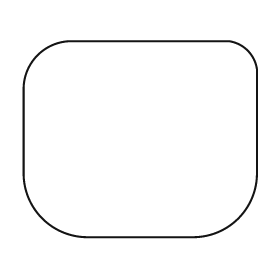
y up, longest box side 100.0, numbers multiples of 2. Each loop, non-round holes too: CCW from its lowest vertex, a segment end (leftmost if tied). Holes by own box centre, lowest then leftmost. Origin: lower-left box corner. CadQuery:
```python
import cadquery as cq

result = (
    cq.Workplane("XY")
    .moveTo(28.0, 0.0)
    .lineTo(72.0, 0.0)
    .threePointArc((92.0, 8.0), (100.0, 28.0))
    .lineTo(100.0, 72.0)
    .threePointArc((96.0, 80.0), (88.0, 84.0))
    .lineTo(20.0, 84.0)
    .threePointArc((6.0, 78.0), (0.0, 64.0))
    .lineTo(0.0, 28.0)
    .threePointArc((8.0, 8.0), (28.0, 0.0))
    .close()
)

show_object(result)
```